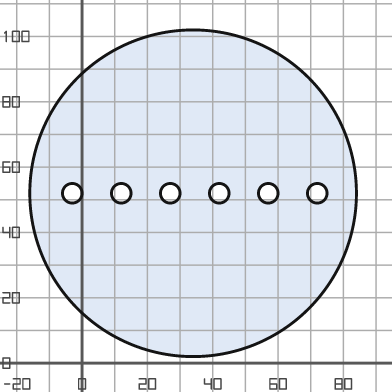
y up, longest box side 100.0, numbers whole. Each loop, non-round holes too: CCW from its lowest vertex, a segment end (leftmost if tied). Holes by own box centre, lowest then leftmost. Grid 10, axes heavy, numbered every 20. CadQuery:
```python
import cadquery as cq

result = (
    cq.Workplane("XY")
    .moveTo(34.0, 52.0)
    .circle(50.0)
    .moveTo(-3.0, 52.0)
    .circle(3.0)
    .moveTo(12.0, 52.0)
    .circle(3.0)
    .moveTo(27.0, 52.0)
    .circle(3.0)
    .moveTo(42.0, 52.0)
    .circle(3.0)
    .moveTo(57.0, 52.0)
    .circle(3.0)
    .moveTo(72.0, 52.0)
    .circle(3.0)
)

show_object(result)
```